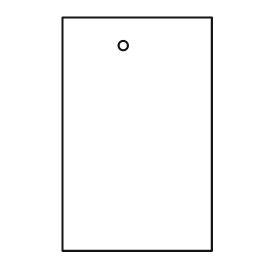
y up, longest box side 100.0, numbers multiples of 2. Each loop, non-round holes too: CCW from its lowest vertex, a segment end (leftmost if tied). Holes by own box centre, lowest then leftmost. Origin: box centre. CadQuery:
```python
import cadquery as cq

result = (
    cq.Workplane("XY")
    .moveTo(-32.0, -50.0)
    .lineTo(32.0, -50.0)
    .lineTo(32.0, 50.0)
    .lineTo(-32.0, 50.0)
    .close()
    .moveTo(-6.0, 38.0)
    .circle(2.0)
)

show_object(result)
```